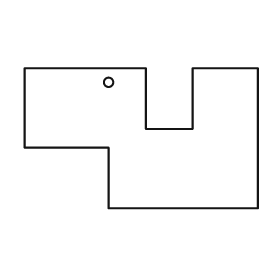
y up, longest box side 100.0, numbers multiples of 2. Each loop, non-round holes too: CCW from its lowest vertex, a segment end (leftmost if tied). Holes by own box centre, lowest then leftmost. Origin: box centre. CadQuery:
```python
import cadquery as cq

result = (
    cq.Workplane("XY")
    .moveTo(-14.0, -30.0)
    .lineTo(50.0, -30.0)
    .lineTo(50.0, 30.0)
    .lineTo(22.0, 30.0)
    .lineTo(22.0, 4.0)
    .lineTo(2.0, 4.0)
    .lineTo(2.0, 30.0)
    .lineTo(-50.0, 30.0)
    .lineTo(-50.0, -4.0)
    .lineTo(-14.0, -4.0)
    .close()
    .moveTo(-14.0, 24.0)
    .circle(2.0)
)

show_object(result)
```